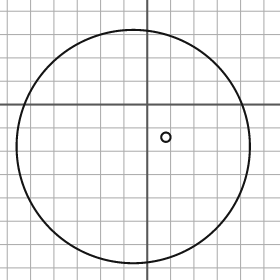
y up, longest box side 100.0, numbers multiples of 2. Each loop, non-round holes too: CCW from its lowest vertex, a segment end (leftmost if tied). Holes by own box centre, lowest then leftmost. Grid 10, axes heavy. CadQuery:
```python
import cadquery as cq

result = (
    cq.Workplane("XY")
    .moveTo(-6.0, -18.0)
    .circle(50.0)
    .moveTo(8.0, -14.0)
    .circle(2.0)
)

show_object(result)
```